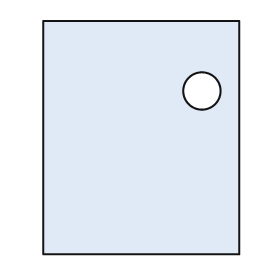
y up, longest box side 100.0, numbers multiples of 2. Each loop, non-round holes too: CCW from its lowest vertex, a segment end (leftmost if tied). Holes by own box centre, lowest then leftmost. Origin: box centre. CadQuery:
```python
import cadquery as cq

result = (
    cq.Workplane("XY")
    .moveTo(-42.0, -50.0)
    .lineTo(42.0, -50.0)
    .lineTo(42.0, 50.0)
    .lineTo(-42.0, 50.0)
    .close()
    .moveTo(26.0, 20.0)
    .circle(8.0)
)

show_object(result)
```